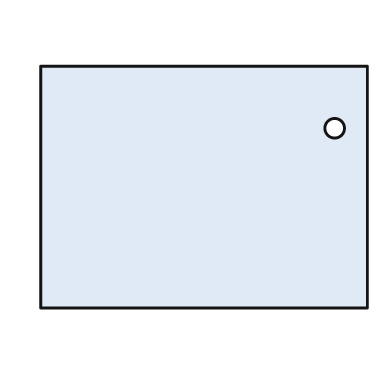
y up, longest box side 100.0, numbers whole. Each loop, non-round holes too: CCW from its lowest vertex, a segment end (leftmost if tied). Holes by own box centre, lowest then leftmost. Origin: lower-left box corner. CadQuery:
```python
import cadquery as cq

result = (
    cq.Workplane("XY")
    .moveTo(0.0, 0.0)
    .lineTo(100.0, 0.0)
    .lineTo(100.0, 74.0)
    .lineTo(0.0, 74.0)
    .close()
    .moveTo(90.0, 55.0)
    .circle(3.0)
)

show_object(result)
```